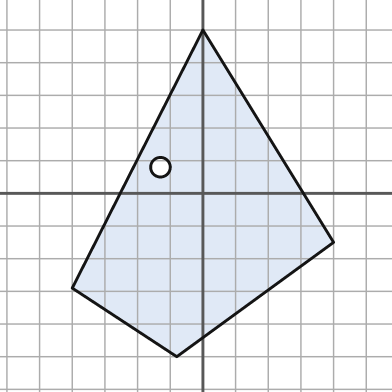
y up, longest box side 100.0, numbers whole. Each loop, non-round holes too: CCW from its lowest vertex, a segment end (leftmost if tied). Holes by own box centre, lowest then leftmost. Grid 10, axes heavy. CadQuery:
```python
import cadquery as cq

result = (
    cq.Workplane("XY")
    .moveTo(-8.0, -50.0)
    .lineTo(40.0, -15.0)
    .lineTo(0.0, 50.0)
    .lineTo(-40.0, -29.0)
    .close()
    .moveTo(-13.0, 8.0)
    .circle(3.0)
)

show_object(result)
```